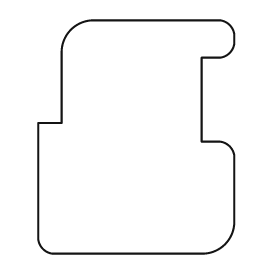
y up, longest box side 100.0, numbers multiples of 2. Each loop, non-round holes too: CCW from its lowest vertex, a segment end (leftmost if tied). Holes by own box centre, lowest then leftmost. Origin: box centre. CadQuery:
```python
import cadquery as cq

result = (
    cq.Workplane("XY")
    .moveTo(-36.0, -50.0)
    .lineTo(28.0, -50.0)
    .threePointArc((38.0, -46.0), (42.0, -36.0))
    .lineTo(42.0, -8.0)
    .threePointArc((40.0, -4.0), (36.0, -2.0))
    .lineTo(28.0, -2.0)
    .lineTo(28.0, 34.0)
    .lineTo(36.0, 34.0)
    .threePointArc((40.0, 36.0), (42.0, 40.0))
    .lineTo(42.0, 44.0)
    .threePointArc((40.0, 48.0), (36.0, 50.0))
    .lineTo(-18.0, 50.0)
    .threePointArc((-28.0, 46.0), (-32.0, 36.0))
    .lineTo(-32.0, 6.0)
    .lineTo(-42.0, 6.0)
    .lineTo(-42.0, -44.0)
    .threePointArc((-40.0, -48.0), (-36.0, -50.0))
    .close()
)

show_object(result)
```